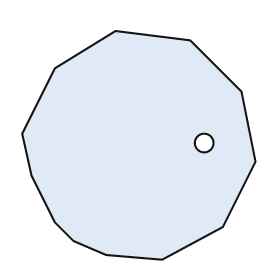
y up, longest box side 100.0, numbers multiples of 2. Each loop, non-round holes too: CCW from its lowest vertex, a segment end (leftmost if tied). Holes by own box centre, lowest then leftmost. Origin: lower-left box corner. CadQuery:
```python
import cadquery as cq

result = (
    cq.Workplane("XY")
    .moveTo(60.0, 0.0)
    .lineTo(86.0, 14.0)
    .lineTo(100.0, 42.0)
    .lineTo(94.0, 72.0)
    .lineTo(72.0, 94.0)
    .lineTo(40.0, 98.0)
    .lineTo(14.0, 82.0)
    .lineTo(0.0, 54.0)
    .lineTo(4.0, 36.0)
    .lineTo(14.0, 16.0)
    .lineTo(22.0, 8.0)
    .lineTo(36.0, 2.0)
    .close()
    .moveTo(78.0, 50.0)
    .circle(4.0)
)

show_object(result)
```